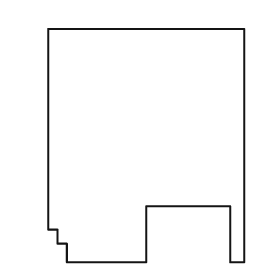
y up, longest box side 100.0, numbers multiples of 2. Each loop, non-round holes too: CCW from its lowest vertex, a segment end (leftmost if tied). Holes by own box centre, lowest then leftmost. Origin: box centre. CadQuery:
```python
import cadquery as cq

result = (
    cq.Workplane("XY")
    .moveTo(-34.0, -50.0)
    .lineTo(0.0, -50.0)
    .lineTo(0.0, -26.0)
    .lineTo(36.0, -26.0)
    .lineTo(36.0, -50.0)
    .lineTo(42.0, -50.0)
    .lineTo(42.0, 50.0)
    .lineTo(-42.0, 50.0)
    .lineTo(-42.0, -36.0)
    .lineTo(-38.0, -36.0)
    .lineTo(-38.0, -42.0)
    .lineTo(-34.0, -42.0)
    .close()
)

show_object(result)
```